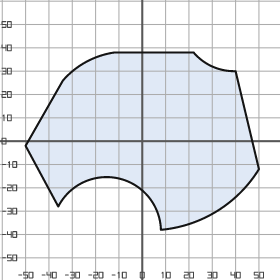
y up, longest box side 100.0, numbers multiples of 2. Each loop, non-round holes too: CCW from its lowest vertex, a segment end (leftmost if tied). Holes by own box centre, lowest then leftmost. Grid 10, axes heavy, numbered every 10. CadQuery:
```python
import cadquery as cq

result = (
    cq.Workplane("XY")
    .moveTo(8.0, -38.0)
    .threePointArc((32.0, -30.0), (50.0, -12.0))
    .lineTo(40.0, 30.0)
    .threePointArc((30.0, 32.0), (22.0, 38.0))
    .lineTo(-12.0, 38.0)
    .threePointArc((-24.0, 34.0), (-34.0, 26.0))
    .lineTo(-50.0, -2.0)
    .lineTo(-36.0, -28.0)
    .threePointArc((-10.0, -16.0), (8.0, -38.0))
    .close()
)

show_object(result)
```